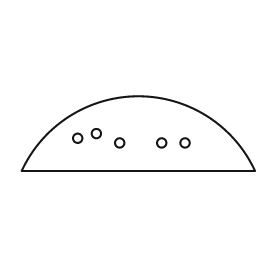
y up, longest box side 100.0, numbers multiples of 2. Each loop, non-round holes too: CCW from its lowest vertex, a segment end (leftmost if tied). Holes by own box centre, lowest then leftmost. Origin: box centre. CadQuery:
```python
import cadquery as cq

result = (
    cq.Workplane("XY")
    .moveTo(-50.0, -16.0)
    .lineTo(50.0, -16.0)
    .threePointArc((0.0, 16.0), (-50.0, -16.0))
    .close()
    .moveTo(-8.0, -4.0)
    .circle(2.0)
    .moveTo(10.0, -4.0)
    .circle(2.0)
    .moveTo(20.0, -4.0)
    .circle(2.0)
    .moveTo(-26.0, -2.0)
    .circle(2.0)
    .moveTo(-18.0, 0.0)
    .circle(2.0)
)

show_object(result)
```